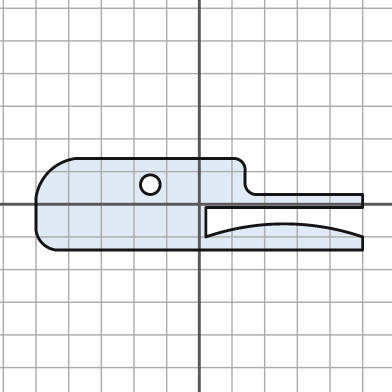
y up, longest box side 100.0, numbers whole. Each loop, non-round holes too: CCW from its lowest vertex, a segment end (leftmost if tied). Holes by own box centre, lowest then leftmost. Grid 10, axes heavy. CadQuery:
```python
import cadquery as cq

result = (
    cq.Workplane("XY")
    .moveTo(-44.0, -14.0)
    .lineTo(50.0, -14.0)
    .lineTo(50.0, -10.0)
    .threePointArc((26.0, -6.0), (2.0, -10.0))
    .lineTo(2.0, -1.0)
    .lineTo(50.0, -1.0)
    .lineTo(50.0, 3.0)
    .lineTo(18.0, 3.0)
    .threePointArc((15.0, 4.0), (14.0, 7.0))
    .lineTo(14.0, 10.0)
    .threePointArc((13.0, 13.0), (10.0, 14.0))
    .lineTo(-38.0, 14.0)
    .threePointArc((-46.0, 10.0), (-50.0, 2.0))
    .lineTo(-50.0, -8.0)
    .threePointArc((-48.0, -12.0), (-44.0, -14.0))
    .close()
    .moveTo(-15.0, 6.0)
    .circle(3.0)
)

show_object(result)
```